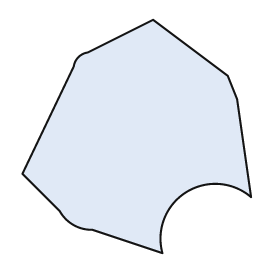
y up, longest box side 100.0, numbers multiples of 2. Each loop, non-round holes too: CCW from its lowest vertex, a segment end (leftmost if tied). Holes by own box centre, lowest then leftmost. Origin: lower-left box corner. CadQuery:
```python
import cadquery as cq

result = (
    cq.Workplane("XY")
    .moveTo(60.0, 0.0)
    .threePointArc((70.0, 26.0), (98.0, 24.0))
    .lineTo(92.0, 66.0)
    .lineTo(88.0, 76.0)
    .lineTo(56.0, 100.0)
    .lineTo(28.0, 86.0)
    .threePointArc((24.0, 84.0), (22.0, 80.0))
    .lineTo(0.0, 34.0)
    .lineTo(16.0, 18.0)
    .threePointArc((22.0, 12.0), (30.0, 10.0))
    .close()
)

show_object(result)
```